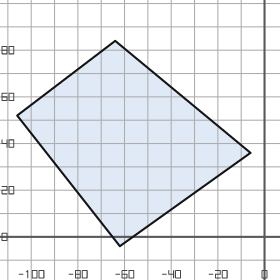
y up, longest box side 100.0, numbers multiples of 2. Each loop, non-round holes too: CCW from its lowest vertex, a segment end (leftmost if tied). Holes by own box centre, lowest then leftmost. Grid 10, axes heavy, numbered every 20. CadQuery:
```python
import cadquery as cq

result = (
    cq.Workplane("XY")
    .moveTo(-62.0, -4.0)
    .lineTo(-6.0, 36.0)
    .lineTo(-64.0, 84.0)
    .lineTo(-106.0, 52.0)
    .close()
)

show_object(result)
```